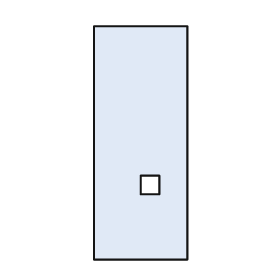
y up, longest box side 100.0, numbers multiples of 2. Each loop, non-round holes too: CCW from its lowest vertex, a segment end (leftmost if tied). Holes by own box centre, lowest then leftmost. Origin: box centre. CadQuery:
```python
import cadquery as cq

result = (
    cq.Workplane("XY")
    .moveTo(-20.0, -50.0)
    .lineTo(20.0, -50.0)
    .lineTo(20.0, 50.0)
    .lineTo(-20.0, 50.0)
    .close()
    .moveTo(0.0, -22.0)
    .lineTo(8.0, -22.0)
    .lineTo(8.0, -14.0)
    .lineTo(0.0, -14.0)
    .close()
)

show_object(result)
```